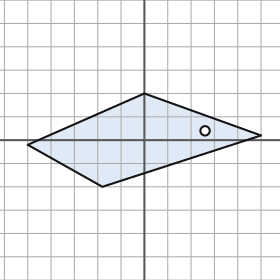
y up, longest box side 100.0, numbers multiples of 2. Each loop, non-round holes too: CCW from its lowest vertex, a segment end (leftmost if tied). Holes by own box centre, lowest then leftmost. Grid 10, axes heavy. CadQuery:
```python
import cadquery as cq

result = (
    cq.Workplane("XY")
    .moveTo(-18.0, -20.0)
    .lineTo(50.0, 2.0)
    .lineTo(0.0, 20.0)
    .lineTo(-50.0, -2.0)
    .close()
    .moveTo(26.0, 4.0)
    .circle(2.0)
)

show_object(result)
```